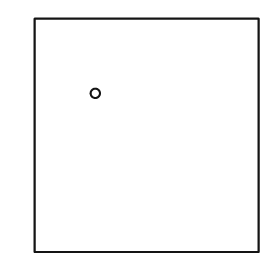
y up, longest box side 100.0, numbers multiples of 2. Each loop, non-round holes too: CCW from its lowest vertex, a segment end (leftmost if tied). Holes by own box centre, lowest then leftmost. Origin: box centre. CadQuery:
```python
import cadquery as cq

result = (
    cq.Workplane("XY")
    .moveTo(-48.0, -50.0)
    .lineTo(48.0, -50.0)
    .lineTo(48.0, 50.0)
    .lineTo(-48.0, 50.0)
    .close()
    .moveTo(-22.0, 18.0)
    .circle(2.0)
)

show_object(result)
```